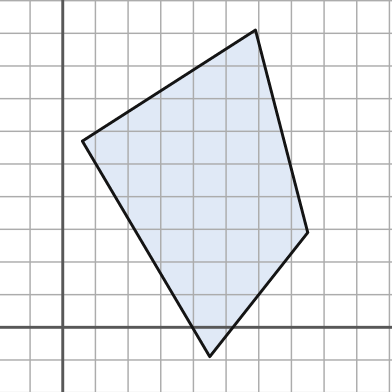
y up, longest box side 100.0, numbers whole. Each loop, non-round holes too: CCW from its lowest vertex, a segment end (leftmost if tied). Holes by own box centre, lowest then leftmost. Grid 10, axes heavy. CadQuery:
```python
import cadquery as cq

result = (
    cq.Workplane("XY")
    .moveTo(45.0, -9.0)
    .lineTo(75.0, 29.0)
    .lineTo(59.0, 91.0)
    .lineTo(6.0, 57.0)
    .close()
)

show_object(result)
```